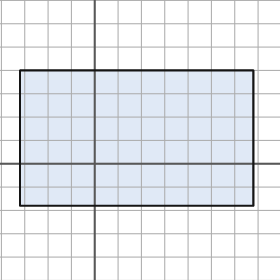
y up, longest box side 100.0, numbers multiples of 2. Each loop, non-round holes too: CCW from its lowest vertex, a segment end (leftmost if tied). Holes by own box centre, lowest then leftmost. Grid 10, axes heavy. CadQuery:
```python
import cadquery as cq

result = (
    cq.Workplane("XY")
    .moveTo(-32.0, -18.0)
    .lineTo(68.0, -18.0)
    .lineTo(68.0, 40.0)
    .lineTo(-32.0, 40.0)
    .close()
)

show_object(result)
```